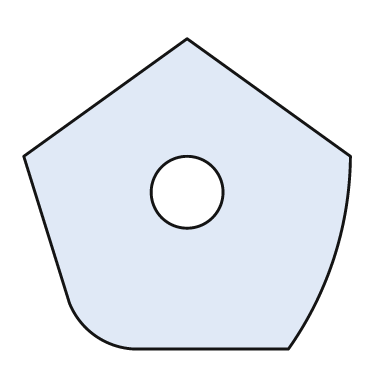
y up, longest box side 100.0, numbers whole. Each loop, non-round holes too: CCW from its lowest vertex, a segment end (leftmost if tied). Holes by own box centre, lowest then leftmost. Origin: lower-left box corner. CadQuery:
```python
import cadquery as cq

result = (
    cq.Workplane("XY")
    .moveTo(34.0, 0.0)
    .lineTo(81.0, 0.0)
    .threePointArc((95.0, 28.0), (100.0, 59.0))
    .lineTo(50.0, 95.0)
    .lineTo(0.0, 59.0)
    .lineTo(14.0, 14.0)
    .threePointArc((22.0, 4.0), (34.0, 0.0))
    .close()
    .moveTo(50.0, 48.0)
    .circle(11.0)
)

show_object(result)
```